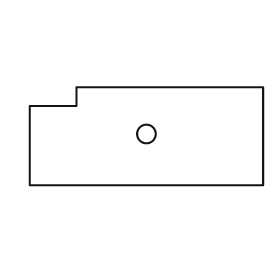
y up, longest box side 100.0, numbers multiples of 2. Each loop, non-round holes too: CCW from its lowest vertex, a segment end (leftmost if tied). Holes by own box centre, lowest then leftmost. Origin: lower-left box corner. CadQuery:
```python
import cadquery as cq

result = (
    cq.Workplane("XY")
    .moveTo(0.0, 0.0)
    .lineTo(100.0, 0.0)
    .lineTo(100.0, 42.0)
    .lineTo(20.0, 42.0)
    .lineTo(20.0, 34.0)
    .lineTo(0.0, 34.0)
    .close()
    .moveTo(50.0, 22.0)
    .circle(4.0)
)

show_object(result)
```